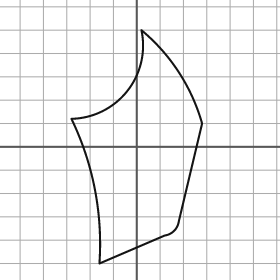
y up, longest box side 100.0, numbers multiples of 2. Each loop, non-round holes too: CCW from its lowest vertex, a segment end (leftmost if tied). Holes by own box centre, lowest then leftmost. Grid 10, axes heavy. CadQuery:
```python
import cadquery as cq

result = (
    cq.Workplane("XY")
    .moveTo(-16.0, -50.0)
    .lineTo(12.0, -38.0)
    .threePointArc((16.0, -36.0), (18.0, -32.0))
    .lineTo(28.0, 10.0)
    .threePointArc((18.0, 32.0), (2.0, 50.0))
    .threePointArc((-4.0, 24.0), (-28.0, 12.0))
    .threePointArc((-18.0, -18.0), (-16.0, -50.0))
    .close()
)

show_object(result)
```